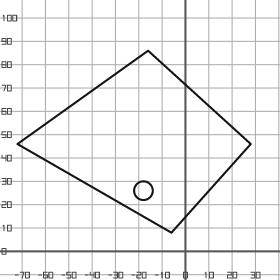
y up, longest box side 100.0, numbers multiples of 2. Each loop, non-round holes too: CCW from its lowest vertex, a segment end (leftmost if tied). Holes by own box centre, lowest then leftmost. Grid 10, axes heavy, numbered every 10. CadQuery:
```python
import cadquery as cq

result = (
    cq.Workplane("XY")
    .moveTo(-6.0, 8.0)
    .lineTo(28.0, 46.0)
    .lineTo(-16.0, 86.0)
    .lineTo(-72.0, 46.0)
    .close()
    .moveTo(-18.0, 26.0)
    .circle(4.0)
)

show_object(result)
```